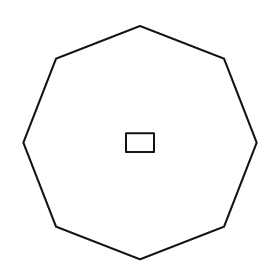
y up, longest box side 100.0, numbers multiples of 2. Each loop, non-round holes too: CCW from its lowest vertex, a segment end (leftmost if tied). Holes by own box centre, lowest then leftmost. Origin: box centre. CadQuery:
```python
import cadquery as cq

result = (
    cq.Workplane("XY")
    .moveTo(0.0, -50.0)
    .lineTo(36.0, -36.0)
    .lineTo(50.0, 0.0)
    .lineTo(36.0, 36.0)
    .lineTo(0.0, 50.0)
    .lineTo(-36.0, 36.0)
    .lineTo(-50.0, 0.0)
    .lineTo(-36.0, -36.0)
    .close()
    .moveTo(-6.0, -4.0)
    .lineTo(6.0, -4.0)
    .lineTo(6.0, 4.0)
    .lineTo(-6.0, 4.0)
    .close()
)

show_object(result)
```